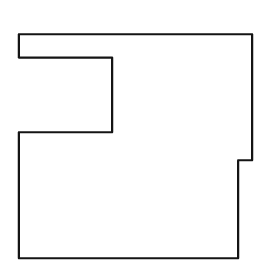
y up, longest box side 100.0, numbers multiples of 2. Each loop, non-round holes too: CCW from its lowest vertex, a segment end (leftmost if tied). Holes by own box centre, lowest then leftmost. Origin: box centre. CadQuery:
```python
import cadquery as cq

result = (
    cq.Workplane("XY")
    .moveTo(-50.0, -48.0)
    .lineTo(44.0, -48.0)
    .lineTo(44.0, -6.0)
    .lineTo(50.0, -6.0)
    .lineTo(50.0, 48.0)
    .lineTo(-50.0, 48.0)
    .lineTo(-50.0, 38.0)
    .lineTo(-10.0, 38.0)
    .lineTo(-10.0, 6.0)
    .lineTo(-50.0, 6.0)
    .close()
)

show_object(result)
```